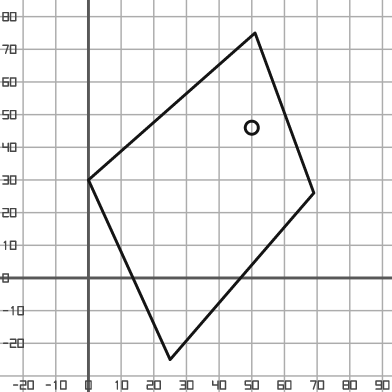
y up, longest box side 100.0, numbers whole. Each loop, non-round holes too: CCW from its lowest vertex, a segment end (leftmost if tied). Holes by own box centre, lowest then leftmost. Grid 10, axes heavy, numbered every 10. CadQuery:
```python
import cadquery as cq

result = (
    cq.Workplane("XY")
    .moveTo(25.0, -25.0)
    .lineTo(69.0, 26.0)
    .lineTo(51.0, 75.0)
    .lineTo(0.0, 30.0)
    .close()
    .moveTo(50.0, 46.0)
    .circle(2.0)
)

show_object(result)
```